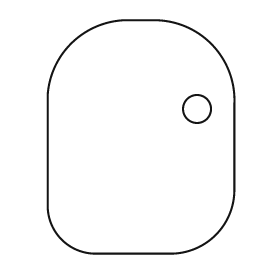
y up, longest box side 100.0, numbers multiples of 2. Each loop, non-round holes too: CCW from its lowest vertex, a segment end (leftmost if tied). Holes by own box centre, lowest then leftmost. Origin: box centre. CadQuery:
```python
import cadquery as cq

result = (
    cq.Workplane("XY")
    .moveTo(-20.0, -50.0)
    .lineTo(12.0, -50.0)
    .threePointArc((32.0, -42.0), (40.0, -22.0))
    .lineTo(40.0, 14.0)
    .threePointArc((30.0, 40.0), (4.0, 50.0))
    .lineTo(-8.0, 50.0)
    .threePointArc((-30.0, 40.0), (-40.0, 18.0))
    .lineTo(-40.0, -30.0)
    .threePointArc((-34.0, -44.0), (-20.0, -50.0))
    .close()
    .moveTo(24.0, 12.0)
    .circle(6.0)
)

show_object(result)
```